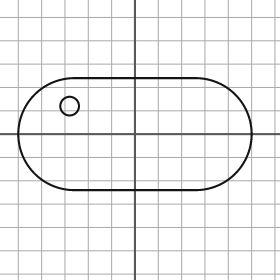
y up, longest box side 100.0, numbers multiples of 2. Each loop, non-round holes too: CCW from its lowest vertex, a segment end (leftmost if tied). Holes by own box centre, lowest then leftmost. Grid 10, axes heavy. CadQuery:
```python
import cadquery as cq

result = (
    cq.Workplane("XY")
    .moveTo(-26.0, -24.0)
    .lineTo(26.0, -24.0)
    .threePointArc((50.0, 0.0), (26.0, 24.0))
    .lineTo(-26.0, 24.0)
    .threePointArc((-50.0, 0.0), (-26.0, -24.0))
    .close()
    .moveTo(-28.0, 12.0)
    .circle(4.0)
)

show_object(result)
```